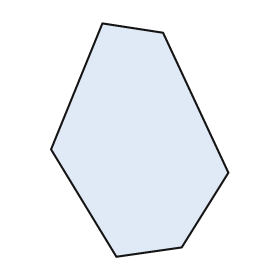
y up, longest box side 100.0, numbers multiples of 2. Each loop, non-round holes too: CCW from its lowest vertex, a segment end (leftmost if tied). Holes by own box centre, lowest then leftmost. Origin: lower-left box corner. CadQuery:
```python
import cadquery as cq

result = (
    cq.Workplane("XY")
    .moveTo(28.0, 0.0)
    .lineTo(56.0, 4.0)
    .lineTo(76.0, 36.0)
    .lineTo(48.0, 96.0)
    .lineTo(22.0, 100.0)
    .lineTo(0.0, 46.0)
    .close()
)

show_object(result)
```